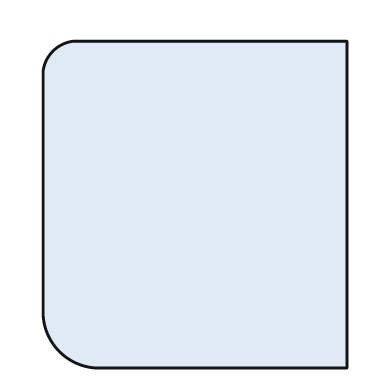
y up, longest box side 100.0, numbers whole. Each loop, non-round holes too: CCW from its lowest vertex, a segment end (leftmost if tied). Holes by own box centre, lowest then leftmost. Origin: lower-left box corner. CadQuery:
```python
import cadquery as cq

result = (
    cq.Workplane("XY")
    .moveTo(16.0, 0.0)
    .lineTo(93.0, 0.0)
    .lineTo(93.0, 100.0)
    .lineTo(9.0, 100.0)
    .threePointArc((3.0, 97.0), (0.0, 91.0))
    .lineTo(0.0, 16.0)
    .threePointArc((5.0, 5.0), (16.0, 0.0))
    .close()
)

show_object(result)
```